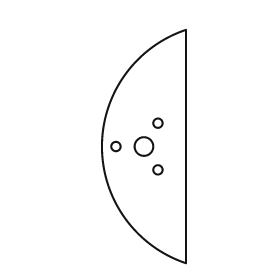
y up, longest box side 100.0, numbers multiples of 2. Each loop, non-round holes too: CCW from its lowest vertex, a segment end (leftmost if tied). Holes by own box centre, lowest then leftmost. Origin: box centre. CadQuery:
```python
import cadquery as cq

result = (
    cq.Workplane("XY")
    .moveTo(18.0, -50.0)
    .lineTo(18.0, 50.0)
    .threePointArc((-18.0, 0.0), (18.0, -50.0))
    .close()
    .moveTo(6.0, -10.0)
    .circle(2.0)
    .moveTo(-12.0, 0.0)
    .circle(2.0)
    .moveTo(0.0, 0.0)
    .circle(4.0)
    .moveTo(6.0, 10.0)
    .circle(2.0)
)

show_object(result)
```